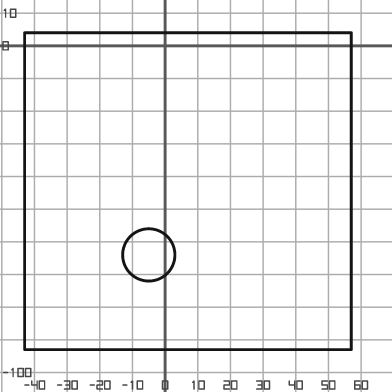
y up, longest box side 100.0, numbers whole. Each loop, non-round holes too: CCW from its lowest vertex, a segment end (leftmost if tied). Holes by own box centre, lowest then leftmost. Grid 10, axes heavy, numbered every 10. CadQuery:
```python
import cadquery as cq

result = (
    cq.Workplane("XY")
    .moveTo(-43.0, -93.0)
    .lineTo(57.0, -93.0)
    .lineTo(57.0, 4.0)
    .lineTo(-43.0, 4.0)
    .close()
    .moveTo(-5.0, -64.0)
    .circle(8.0)
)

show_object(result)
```